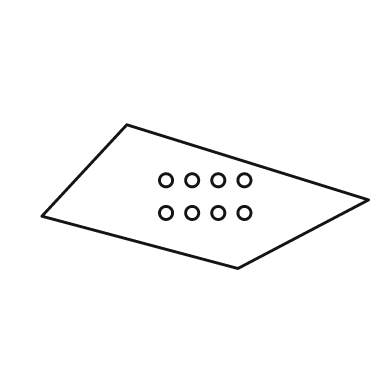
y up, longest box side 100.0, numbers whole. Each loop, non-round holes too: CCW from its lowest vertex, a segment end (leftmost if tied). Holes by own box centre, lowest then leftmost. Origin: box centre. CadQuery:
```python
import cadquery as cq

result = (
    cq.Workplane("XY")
    .moveTo(10.0, -22.0)
    .lineTo(50.0, -1.0)
    .lineTo(-24.0, 22.0)
    .lineTo(-50.0, -6.0)
    .close()
    .moveTo(-12.0, -5.0)
    .circle(2.0)
    .moveTo(-4.0, -5.0)
    .circle(2.0)
    .moveTo(4.0, -5.0)
    .circle(2.0)
    .moveTo(12.0, -5.0)
    .circle(2.0)
    .moveTo(-12.0, 5.0)
    .circle(2.0)
    .moveTo(-4.0, 5.0)
    .circle(2.0)
    .moveTo(4.0, 5.0)
    .circle(2.0)
    .moveTo(12.0, 5.0)
    .circle(2.0)
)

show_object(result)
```